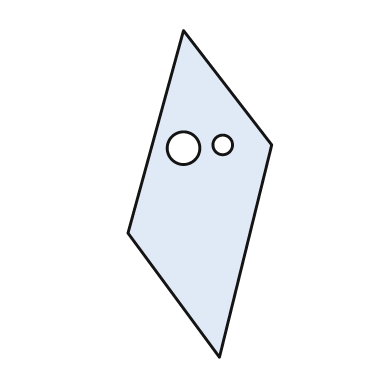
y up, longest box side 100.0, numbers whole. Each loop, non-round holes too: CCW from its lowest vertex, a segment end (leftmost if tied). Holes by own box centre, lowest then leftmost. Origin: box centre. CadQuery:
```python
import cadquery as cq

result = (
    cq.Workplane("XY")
    .moveTo(6.0, -50.0)
    .lineTo(22.0, 15.0)
    .lineTo(-5.0, 50.0)
    .lineTo(-22.0, -12.0)
    .close()
    .moveTo(-5.0, 14.0)
    .circle(5.0)
    .moveTo(7.0, 15.0)
    .circle(3.0)
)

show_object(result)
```